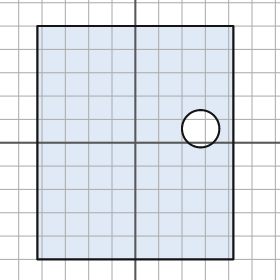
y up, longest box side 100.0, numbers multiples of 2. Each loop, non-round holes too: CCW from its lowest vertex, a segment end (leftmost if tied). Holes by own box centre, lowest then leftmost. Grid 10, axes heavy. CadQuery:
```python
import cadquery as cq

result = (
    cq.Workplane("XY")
    .moveTo(-42.0, -50.0)
    .lineTo(42.0, -50.0)
    .lineTo(42.0, 50.0)
    .lineTo(-42.0, 50.0)
    .close()
    .moveTo(28.0, 6.0)
    .circle(8.0)
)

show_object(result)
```